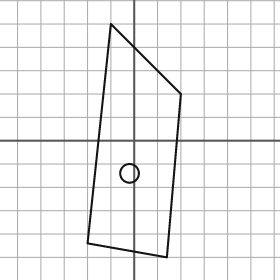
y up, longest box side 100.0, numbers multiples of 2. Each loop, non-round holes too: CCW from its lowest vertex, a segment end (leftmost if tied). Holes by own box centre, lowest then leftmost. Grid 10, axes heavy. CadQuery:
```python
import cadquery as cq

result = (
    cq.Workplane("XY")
    .moveTo(14.0, -50.0)
    .lineTo(20.0, 20.0)
    .lineTo(-10.0, 50.0)
    .lineTo(-20.0, -44.0)
    .close()
    .moveTo(-2.0, -14.0)
    .circle(4.0)
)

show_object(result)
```